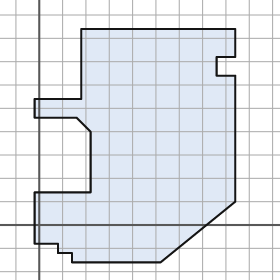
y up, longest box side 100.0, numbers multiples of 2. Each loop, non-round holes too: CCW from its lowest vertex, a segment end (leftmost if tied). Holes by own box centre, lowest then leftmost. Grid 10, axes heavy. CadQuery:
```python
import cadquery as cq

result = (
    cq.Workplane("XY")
    .moveTo(14.0, -16.0)
    .lineTo(52.0, -16.0)
    .lineTo(84.0, 10.0)
    .lineTo(84.0, 64.0)
    .lineTo(76.0, 64.0)
    .lineTo(76.0, 72.0)
    .lineTo(84.0, 72.0)
    .lineTo(84.0, 84.0)
    .lineTo(18.0, 84.0)
    .lineTo(18.0, 54.0)
    .lineTo(-2.0, 54.0)
    .lineTo(-2.0, 46.0)
    .lineTo(16.0, 46.0)
    .lineTo(22.0, 40.0)
    .lineTo(22.0, 14.0)
    .lineTo(-2.0, 14.0)
    .lineTo(-2.0, -8.0)
    .lineTo(8.0, -8.0)
    .lineTo(8.0, -12.0)
    .lineTo(14.0, -12.0)
    .close()
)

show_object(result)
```